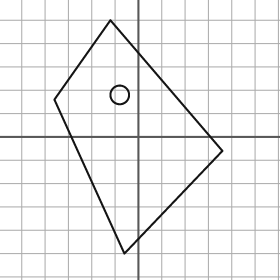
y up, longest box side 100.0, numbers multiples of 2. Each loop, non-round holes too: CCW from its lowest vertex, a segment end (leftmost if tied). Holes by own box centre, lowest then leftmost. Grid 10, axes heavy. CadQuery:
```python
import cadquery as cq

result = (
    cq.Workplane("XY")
    .moveTo(-6.0, -50.0)
    .lineTo(36.0, -6.0)
    .lineTo(-12.0, 50.0)
    .lineTo(-36.0, 16.0)
    .close()
    .moveTo(-8.0, 18.0)
    .circle(4.0)
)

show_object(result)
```